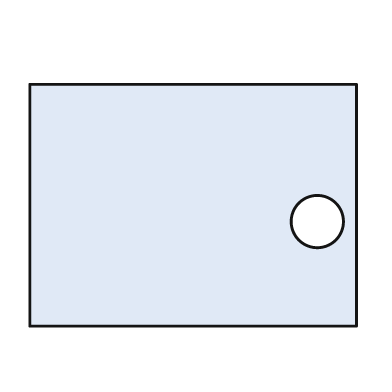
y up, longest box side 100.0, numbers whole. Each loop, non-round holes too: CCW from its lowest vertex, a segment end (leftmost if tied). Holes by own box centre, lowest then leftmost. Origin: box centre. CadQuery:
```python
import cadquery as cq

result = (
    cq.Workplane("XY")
    .moveTo(-50.0, -37.0)
    .lineTo(50.0, -37.0)
    .lineTo(50.0, 37.0)
    .lineTo(-50.0, 37.0)
    .close()
    .moveTo(38.0, -5.0)
    .circle(8.0)
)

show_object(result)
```